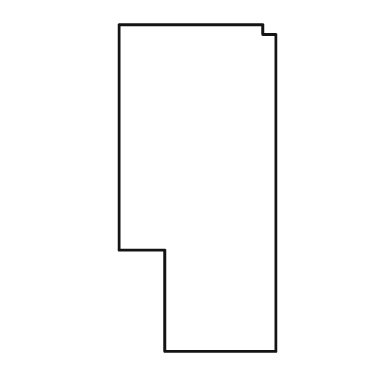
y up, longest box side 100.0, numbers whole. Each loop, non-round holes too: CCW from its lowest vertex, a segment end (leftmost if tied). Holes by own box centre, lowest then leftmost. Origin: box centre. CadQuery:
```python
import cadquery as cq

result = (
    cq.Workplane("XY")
    .moveTo(-10.0, -50.0)
    .lineTo(24.0, -50.0)
    .lineTo(24.0, 47.0)
    .lineTo(20.0, 47.0)
    .lineTo(20.0, 50.0)
    .lineTo(-24.0, 50.0)
    .lineTo(-24.0, -19.0)
    .lineTo(-10.0, -19.0)
    .close()
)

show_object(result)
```